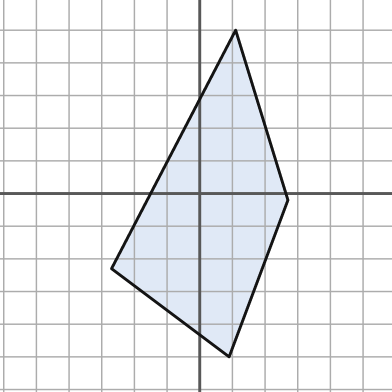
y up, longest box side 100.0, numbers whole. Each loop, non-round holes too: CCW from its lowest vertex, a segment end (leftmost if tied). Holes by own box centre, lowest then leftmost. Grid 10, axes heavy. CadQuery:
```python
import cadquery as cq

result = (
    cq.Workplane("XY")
    .moveTo(9.0, -50.0)
    .lineTo(27.0, -2.0)
    .lineTo(11.0, 50.0)
    .lineTo(-27.0, -23.0)
    .close()
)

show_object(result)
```